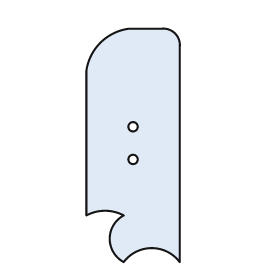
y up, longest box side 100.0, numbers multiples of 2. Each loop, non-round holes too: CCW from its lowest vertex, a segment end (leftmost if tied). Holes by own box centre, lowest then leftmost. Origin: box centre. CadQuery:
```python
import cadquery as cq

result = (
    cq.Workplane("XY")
    .moveTo(-4.0, -50.0)
    .threePointArc((8.0, -44.0), (20.0, -50.0))
    .lineTo(20.0, 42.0)
    .threePointArc((18.0, 48.0), (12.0, 50.0))
    .lineTo(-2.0, 50.0)
    .threePointArc((-14.0, 44.0), (-20.0, 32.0))
    .lineTo(-20.0, -30.0)
    .threePointArc((-12.0, -28.0), (-4.0, -30.0))
    .threePointArc((-10.0, -40.0), (-4.0, -50.0))
    .close()
    .moveTo(0.0, -6.0)
    .circle(2.0)
    .moveTo(0.0, 8.0)
    .circle(2.0)
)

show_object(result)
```